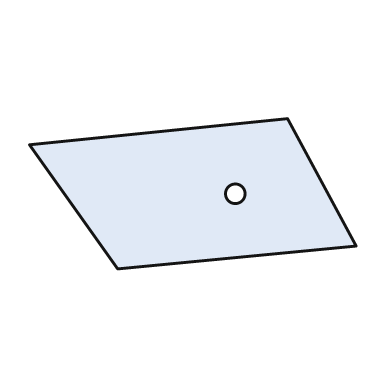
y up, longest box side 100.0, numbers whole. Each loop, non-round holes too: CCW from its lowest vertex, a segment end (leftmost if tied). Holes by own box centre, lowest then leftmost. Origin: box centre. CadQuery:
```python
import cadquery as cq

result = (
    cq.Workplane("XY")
    .moveTo(-23.0, -23.0)
    .lineTo(50.0, -16.0)
    .lineTo(29.0, 23.0)
    .lineTo(-50.0, 15.0)
    .close()
    .moveTo(13.0, 0.0)
    .circle(3.0)
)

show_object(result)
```